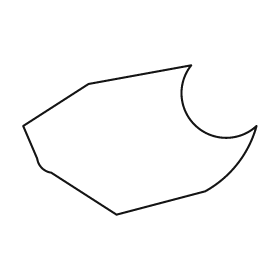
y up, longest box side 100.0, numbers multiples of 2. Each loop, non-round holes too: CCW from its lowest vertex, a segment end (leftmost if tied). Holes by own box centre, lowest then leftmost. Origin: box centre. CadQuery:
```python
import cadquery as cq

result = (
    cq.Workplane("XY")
    .moveTo(-10.0, -32.0)
    .lineTo(28.0, -22.0)
    .threePointArc((42.0, -10.0), (50.0, 6.0))
    .threePointArc((24.0, 6.0), (22.0, 32.0))
    .lineTo(-22.0, 24.0)
    .lineTo(-50.0, 6.0)
    .lineTo(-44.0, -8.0)
    .threePointArc((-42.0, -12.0), (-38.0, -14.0))
    .close()
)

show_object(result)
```